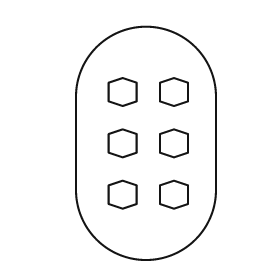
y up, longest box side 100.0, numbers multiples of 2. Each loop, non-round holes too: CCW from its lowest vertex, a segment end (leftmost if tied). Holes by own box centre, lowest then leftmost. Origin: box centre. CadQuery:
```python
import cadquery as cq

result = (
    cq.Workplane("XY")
    .moveTo(-30.0, -20.0)
    .threePointArc((0.0, -50.0), (30.0, -20.0))
    .lineTo(30.0, 20.0)
    .threePointArc((0.0, 50.0), (-30.0, 20.0))
    .close()
    .moveTo(-10.0, -28.0)
    .lineTo(-4.0, -26.0)
    .lineTo(-4.0, -18.0)
    .lineTo(-10.0, -16.0)
    .lineTo(-16.0, -18.0)
    .lineTo(-16.0, -26.0)
    .close()
    .moveTo(12.0, -28.0)
    .lineTo(18.0, -26.0)
    .lineTo(18.0, -18.0)
    .lineTo(12.0, -16.0)
    .lineTo(6.0, -18.0)
    .lineTo(6.0, -26.0)
    .close()
    .moveTo(-10.0, -6.0)
    .lineTo(-4.0, -4.0)
    .lineTo(-4.0, 4.0)
    .lineTo(-10.0, 6.0)
    .lineTo(-16.0, 4.0)
    .lineTo(-16.0, -4.0)
    .close()
    .moveTo(12.0, -6.0)
    .lineTo(18.0, -4.0)
    .lineTo(18.0, 4.0)
    .lineTo(12.0, 6.0)
    .lineTo(6.0, 4.0)
    .lineTo(6.0, -4.0)
    .close()
    .moveTo(-10.0, 16.0)
    .lineTo(-4.0, 18.0)
    .lineTo(-4.0, 26.0)
    .lineTo(-10.0, 28.0)
    .lineTo(-16.0, 26.0)
    .lineTo(-16.0, 18.0)
    .close()
    .moveTo(12.0, 16.0)
    .lineTo(18.0, 18.0)
    .lineTo(18.0, 26.0)
    .lineTo(12.0, 28.0)
    .lineTo(6.0, 26.0)
    .lineTo(6.0, 18.0)
    .close()
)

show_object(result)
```